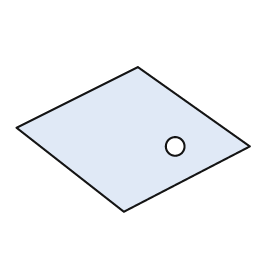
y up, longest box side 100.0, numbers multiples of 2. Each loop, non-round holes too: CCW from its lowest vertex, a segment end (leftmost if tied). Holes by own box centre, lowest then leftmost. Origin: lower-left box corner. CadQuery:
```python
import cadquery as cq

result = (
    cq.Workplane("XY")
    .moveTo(46.0, 0.0)
    .lineTo(100.0, 28.0)
    .lineTo(52.0, 62.0)
    .lineTo(0.0, 36.0)
    .close()
    .moveTo(68.0, 28.0)
    .circle(4.0)
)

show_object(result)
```